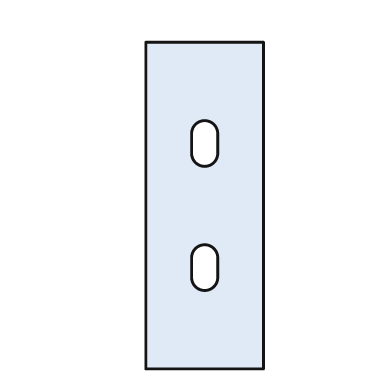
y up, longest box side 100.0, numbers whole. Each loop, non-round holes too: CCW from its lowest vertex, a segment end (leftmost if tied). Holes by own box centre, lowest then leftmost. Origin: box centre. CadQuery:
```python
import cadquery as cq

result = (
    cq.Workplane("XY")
    .moveTo(-18.0, -50.0)
    .lineTo(18.0, -50.0)
    .lineTo(18.0, 50.0)
    .lineTo(-18.0, 50.0)
    .close()
    .moveTo(-4.0, -22.0)
    .threePointArc((0.0, -26.0), (4.0, -22.0))
    .lineTo(4.0, -16.0)
    .threePointArc((0.0, -12.0), (-4.0, -16.0))
    .close()
    .moveTo(-4.0, 16.0)
    .threePointArc((0.0, 12.0), (4.0, 16.0))
    .lineTo(4.0, 22.0)
    .threePointArc((0.0, 26.0), (-4.0, 22.0))
    .close()
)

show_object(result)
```